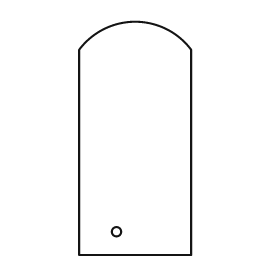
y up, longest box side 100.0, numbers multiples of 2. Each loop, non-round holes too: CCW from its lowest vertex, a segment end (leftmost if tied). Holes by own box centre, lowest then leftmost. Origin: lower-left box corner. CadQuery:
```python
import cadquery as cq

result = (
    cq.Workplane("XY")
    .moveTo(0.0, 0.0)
    .lineTo(48.0, 0.0)
    .lineTo(48.0, 88.0)
    .threePointArc((24.0, 100.0), (0.0, 88.0))
    .close()
    .moveTo(16.0, 10.0)
    .circle(2.0)
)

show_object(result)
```